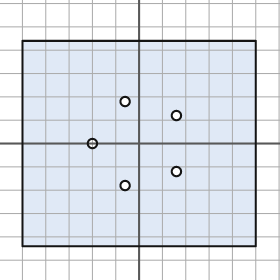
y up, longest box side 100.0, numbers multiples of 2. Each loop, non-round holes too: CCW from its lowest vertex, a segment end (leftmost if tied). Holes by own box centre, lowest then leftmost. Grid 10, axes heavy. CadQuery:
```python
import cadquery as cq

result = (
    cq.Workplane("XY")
    .moveTo(-50.0, -44.0)
    .lineTo(50.0, -44.0)
    .lineTo(50.0, 44.0)
    .lineTo(-50.0, 44.0)
    .close()
    .moveTo(-6.0, -18.0)
    .circle(2.0)
    .moveTo(16.0, -12.0)
    .circle(2.0)
    .moveTo(-20.0, 0.0)
    .circle(2.0)
    .moveTo(16.0, 12.0)
    .circle(2.0)
    .moveTo(-6.0, 18.0)
    .circle(2.0)
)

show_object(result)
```